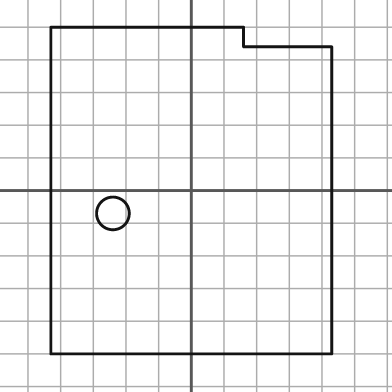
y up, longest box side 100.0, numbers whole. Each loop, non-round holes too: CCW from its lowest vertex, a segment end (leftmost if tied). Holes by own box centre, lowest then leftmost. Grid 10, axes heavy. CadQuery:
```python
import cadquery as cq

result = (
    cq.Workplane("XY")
    .moveTo(-43.0, -50.0)
    .lineTo(43.0, -50.0)
    .lineTo(43.0, 44.0)
    .lineTo(16.0, 44.0)
    .lineTo(16.0, 50.0)
    .lineTo(-43.0, 50.0)
    .close()
    .moveTo(-24.0, -7.0)
    .circle(5.0)
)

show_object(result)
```